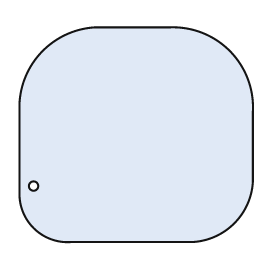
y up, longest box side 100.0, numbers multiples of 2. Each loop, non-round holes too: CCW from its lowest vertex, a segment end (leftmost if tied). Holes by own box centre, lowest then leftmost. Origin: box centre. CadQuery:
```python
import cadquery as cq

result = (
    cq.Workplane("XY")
    .moveTo(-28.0, -46.0)
    .lineTo(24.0, -46.0)
    .threePointArc((42.0, -38.0), (50.0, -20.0))
    .lineTo(50.0, 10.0)
    .threePointArc((40.0, 36.0), (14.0, 46.0))
    .lineTo(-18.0, 46.0)
    .threePointArc((-40.0, 36.0), (-50.0, 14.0))
    .lineTo(-50.0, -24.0)
    .threePointArc((-44.0, -40.0), (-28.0, -46.0))
    .close()
    .moveTo(-44.0, -22.0)
    .circle(2.0)
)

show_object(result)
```